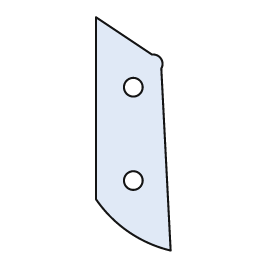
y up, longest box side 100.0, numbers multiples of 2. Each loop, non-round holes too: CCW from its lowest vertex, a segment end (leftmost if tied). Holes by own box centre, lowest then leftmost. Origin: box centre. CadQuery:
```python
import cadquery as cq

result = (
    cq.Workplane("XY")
    .moveTo(16.0, -50.0)
    .lineTo(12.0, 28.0)
    .threePointArc((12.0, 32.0), (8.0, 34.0))
    .lineTo(-16.0, 50.0)
    .lineTo(-16.0, -28.0)
    .threePointArc((-2.0, -42.0), (16.0, -50.0))
    .close()
    .moveTo(0.0, -20.0)
    .circle(4.0)
    .moveTo(0.0, 20.0)
    .circle(4.0)
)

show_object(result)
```